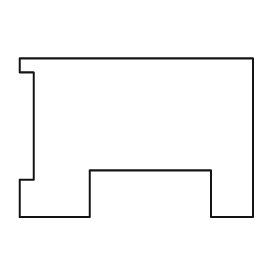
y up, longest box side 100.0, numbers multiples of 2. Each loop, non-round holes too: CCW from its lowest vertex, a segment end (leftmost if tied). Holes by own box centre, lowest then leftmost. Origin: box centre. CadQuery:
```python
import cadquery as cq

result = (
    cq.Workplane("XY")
    .moveTo(-50.0, -34.0)
    .lineTo(-20.0, -34.0)
    .lineTo(-20.0, -14.0)
    .lineTo(32.0, -14.0)
    .lineTo(32.0, -34.0)
    .lineTo(50.0, -34.0)
    .lineTo(50.0, 34.0)
    .lineTo(-50.0, 34.0)
    .lineTo(-50.0, 28.0)
    .lineTo(-44.0, 28.0)
    .lineTo(-44.0, -18.0)
    .lineTo(-50.0, -18.0)
    .close()
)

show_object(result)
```